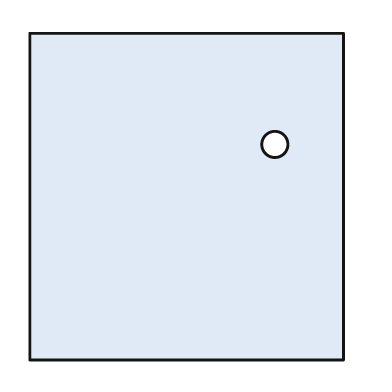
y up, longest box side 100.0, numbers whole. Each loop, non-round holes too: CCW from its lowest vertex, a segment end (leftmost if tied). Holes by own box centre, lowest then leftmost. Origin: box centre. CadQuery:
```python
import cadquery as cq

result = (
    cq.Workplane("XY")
    .moveTo(-48.0, -50.0)
    .lineTo(48.0, -50.0)
    .lineTo(48.0, 50.0)
    .lineTo(-48.0, 50.0)
    .close()
    .moveTo(27.0, 16.0)
    .circle(4.0)
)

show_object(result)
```